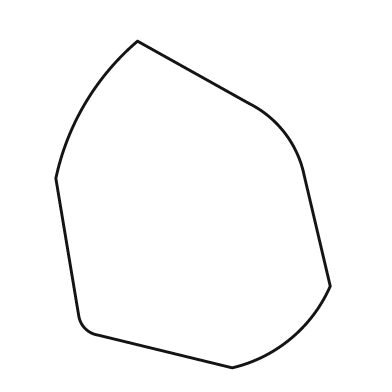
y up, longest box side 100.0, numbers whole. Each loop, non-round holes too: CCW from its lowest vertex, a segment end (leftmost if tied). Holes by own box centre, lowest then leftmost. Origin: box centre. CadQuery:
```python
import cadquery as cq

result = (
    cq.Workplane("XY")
    .moveTo(12.0, -50.0)
    .threePointArc((30.0, -41.0), (42.0, -25.0))
    .lineTo(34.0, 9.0)
    .threePointArc((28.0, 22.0), (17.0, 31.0))
    .lineTo(-17.0, 50.0)
    .threePointArc((-33.0, 31.0), (-42.0, 8.0))
    .lineTo(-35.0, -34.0)
    .threePointArc((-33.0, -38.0), (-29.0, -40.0))
    .close()
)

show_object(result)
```